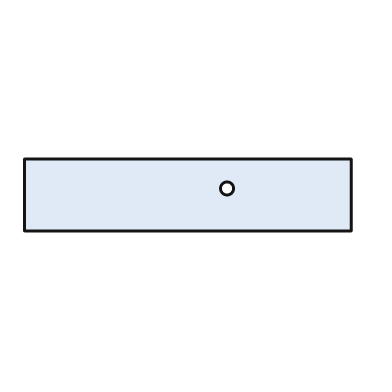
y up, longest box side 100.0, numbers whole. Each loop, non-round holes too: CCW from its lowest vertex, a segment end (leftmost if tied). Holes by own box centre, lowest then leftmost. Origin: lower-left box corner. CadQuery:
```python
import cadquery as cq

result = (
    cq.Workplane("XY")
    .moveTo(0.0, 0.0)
    .lineTo(100.0, 0.0)
    .lineTo(100.0, 22.0)
    .lineTo(0.0, 22.0)
    .close()
    .moveTo(62.0, 13.0)
    .circle(2.0)
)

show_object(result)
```